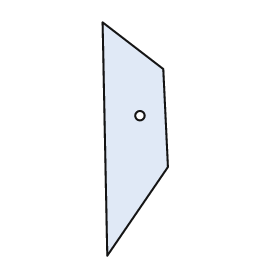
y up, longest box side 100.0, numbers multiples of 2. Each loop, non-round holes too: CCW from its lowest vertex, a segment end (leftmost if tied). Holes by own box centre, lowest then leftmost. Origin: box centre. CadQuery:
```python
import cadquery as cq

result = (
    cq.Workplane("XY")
    .moveTo(-12.0, -50.0)
    .lineTo(14.0, -12.0)
    .lineTo(12.0, 30.0)
    .lineTo(-14.0, 50.0)
    .close()
    .moveTo(2.0, 10.0)
    .circle(2.0)
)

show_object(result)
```